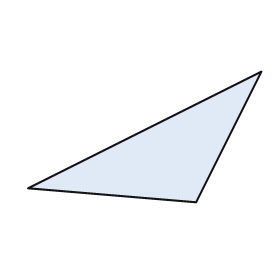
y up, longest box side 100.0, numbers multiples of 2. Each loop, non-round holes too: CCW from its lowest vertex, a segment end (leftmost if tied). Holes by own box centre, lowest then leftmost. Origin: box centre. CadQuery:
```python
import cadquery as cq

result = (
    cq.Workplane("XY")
    .moveTo(22.0, -28.0)
    .lineTo(50.0, 28.0)
    .lineTo(-50.0, -22.0)
    .close()
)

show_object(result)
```